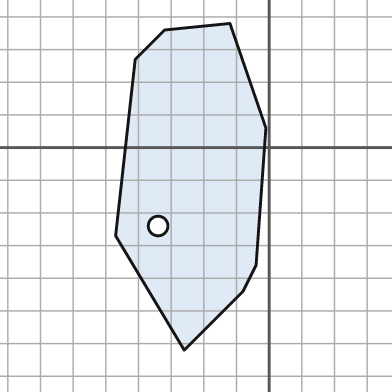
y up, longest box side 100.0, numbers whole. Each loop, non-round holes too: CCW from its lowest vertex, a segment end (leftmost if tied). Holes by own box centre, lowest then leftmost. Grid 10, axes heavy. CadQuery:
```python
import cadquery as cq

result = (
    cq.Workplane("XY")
    .moveTo(-26.0, -62.0)
    .lineTo(-8.0, -44.0)
    .lineTo(-4.0, -36.0)
    .lineTo(-1.0, 6.0)
    .lineTo(-12.0, 38.0)
    .lineTo(-32.0, 36.0)
    .lineTo(-41.0, 27.0)
    .lineTo(-47.0, -27.0)
    .close()
    .moveTo(-34.0, -24.0)
    .circle(3.0)
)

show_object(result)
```